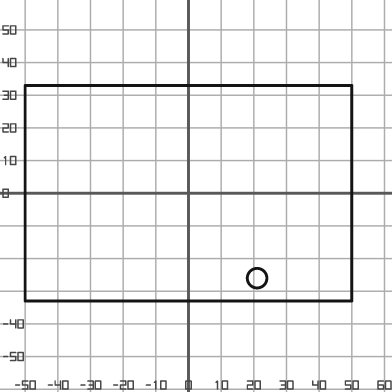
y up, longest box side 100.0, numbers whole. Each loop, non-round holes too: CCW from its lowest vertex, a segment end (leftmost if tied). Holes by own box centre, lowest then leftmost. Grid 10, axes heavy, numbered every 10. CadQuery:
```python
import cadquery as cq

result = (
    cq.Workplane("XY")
    .moveTo(-50.0, -33.0)
    .lineTo(50.0, -33.0)
    .lineTo(50.0, 33.0)
    .lineTo(-50.0, 33.0)
    .close()
    .moveTo(21.0, -26.0)
    .circle(3.0)
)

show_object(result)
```